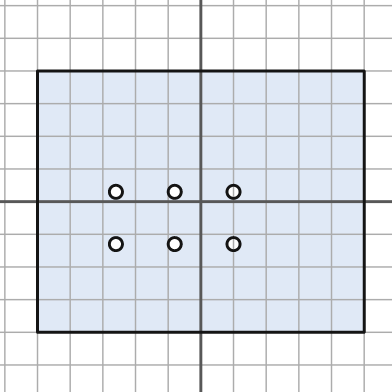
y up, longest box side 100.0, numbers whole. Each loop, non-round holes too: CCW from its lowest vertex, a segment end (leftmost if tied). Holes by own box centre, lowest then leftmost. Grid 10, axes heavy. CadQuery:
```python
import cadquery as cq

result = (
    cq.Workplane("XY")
    .moveTo(-50.0, -40.0)
    .lineTo(50.0, -40.0)
    .lineTo(50.0, 40.0)
    .lineTo(-50.0, 40.0)
    .close()
    .moveTo(-26.0, -13.0)
    .circle(2.0)
    .moveTo(-8.0, -13.0)
    .circle(2.0)
    .moveTo(10.0, -13.0)
    .circle(2.0)
    .moveTo(-26.0, 3.0)
    .circle(2.0)
    .moveTo(-8.0, 3.0)
    .circle(2.0)
    .moveTo(10.0, 3.0)
    .circle(2.0)
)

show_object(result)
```